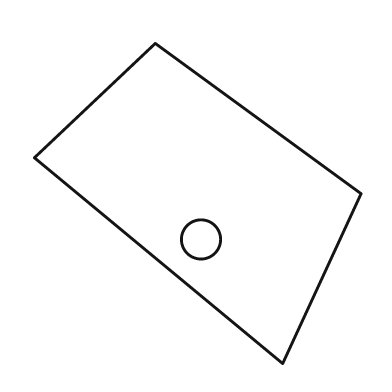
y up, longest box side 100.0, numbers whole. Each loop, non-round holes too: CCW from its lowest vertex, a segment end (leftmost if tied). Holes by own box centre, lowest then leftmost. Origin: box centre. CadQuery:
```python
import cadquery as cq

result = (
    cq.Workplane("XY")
    .moveTo(26.0, -49.0)
    .lineTo(50.0, 3.0)
    .lineTo(-13.0, 49.0)
    .lineTo(-50.0, 14.0)
    .close()
    .moveTo(1.0, -11.0)
    .circle(6.0)
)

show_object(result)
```